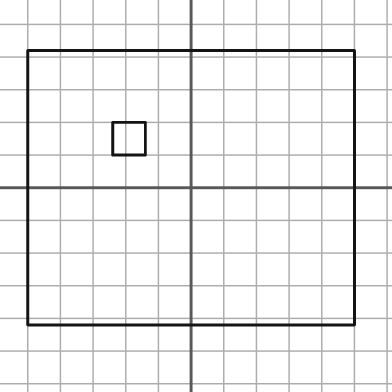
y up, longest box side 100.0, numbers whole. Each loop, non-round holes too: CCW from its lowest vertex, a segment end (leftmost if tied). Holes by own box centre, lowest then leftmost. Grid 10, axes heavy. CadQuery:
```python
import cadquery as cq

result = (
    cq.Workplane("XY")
    .moveTo(-50.0, -42.0)
    .lineTo(50.0, -42.0)
    .lineTo(50.0, 42.0)
    .lineTo(-50.0, 42.0)
    .close()
    .moveTo(-24.0, 10.0)
    .lineTo(-14.0, 10.0)
    .lineTo(-14.0, 20.0)
    .lineTo(-24.0, 20.0)
    .close()
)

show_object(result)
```